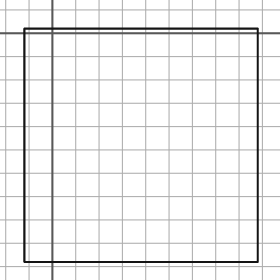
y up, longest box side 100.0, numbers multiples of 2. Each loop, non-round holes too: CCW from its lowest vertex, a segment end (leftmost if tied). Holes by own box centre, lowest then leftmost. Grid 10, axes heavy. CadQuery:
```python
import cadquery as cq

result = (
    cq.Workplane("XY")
    .moveTo(-12.0, -98.0)
    .lineTo(88.0, -98.0)
    .lineTo(88.0, 2.0)
    .lineTo(-12.0, 2.0)
    .close()
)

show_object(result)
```